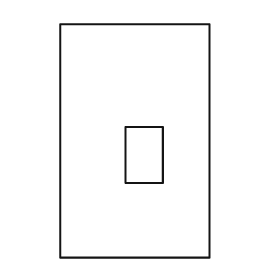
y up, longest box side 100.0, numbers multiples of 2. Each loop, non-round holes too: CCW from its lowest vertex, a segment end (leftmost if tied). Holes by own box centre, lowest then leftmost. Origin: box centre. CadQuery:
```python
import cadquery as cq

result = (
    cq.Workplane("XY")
    .moveTo(-32.0, -50.0)
    .lineTo(32.0, -50.0)
    .lineTo(32.0, 50.0)
    .lineTo(-32.0, 50.0)
    .close()
    .moveTo(-4.0, -18.0)
    .lineTo(12.0, -18.0)
    .lineTo(12.0, 6.0)
    .lineTo(-4.0, 6.0)
    .close()
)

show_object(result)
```